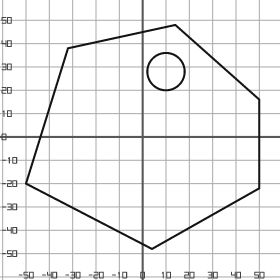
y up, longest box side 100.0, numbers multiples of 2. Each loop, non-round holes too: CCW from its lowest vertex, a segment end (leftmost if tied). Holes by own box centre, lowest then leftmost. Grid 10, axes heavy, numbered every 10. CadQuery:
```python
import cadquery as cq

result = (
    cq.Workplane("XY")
    .moveTo(4.0, -48.0)
    .lineTo(50.0, -22.0)
    .lineTo(50.0, 16.0)
    .lineTo(14.0, 48.0)
    .lineTo(-32.0, 38.0)
    .lineTo(-50.0, -20.0)
    .close()
    .moveTo(10.0, 28.0)
    .circle(8.0)
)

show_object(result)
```